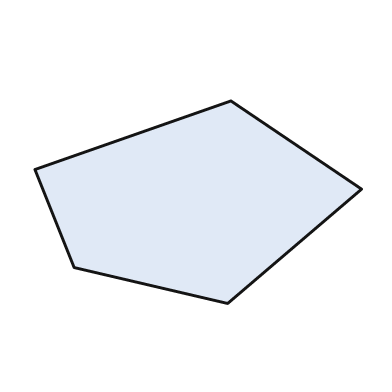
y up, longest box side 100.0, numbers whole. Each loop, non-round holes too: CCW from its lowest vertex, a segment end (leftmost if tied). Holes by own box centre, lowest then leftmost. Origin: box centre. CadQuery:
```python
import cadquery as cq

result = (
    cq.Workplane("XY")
    .moveTo(9.0, -31.0)
    .lineTo(50.0, 4.0)
    .lineTo(10.0, 31.0)
    .lineTo(-50.0, 10.0)
    .lineTo(-38.0, -20.0)
    .close()
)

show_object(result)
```